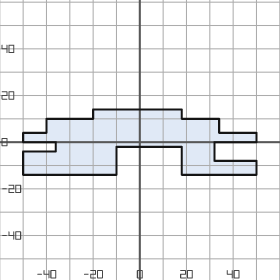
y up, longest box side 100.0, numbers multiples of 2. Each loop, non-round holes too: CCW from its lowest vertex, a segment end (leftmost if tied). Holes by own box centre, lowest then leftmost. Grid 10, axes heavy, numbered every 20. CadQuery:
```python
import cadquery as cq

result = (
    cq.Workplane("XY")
    .moveTo(-50.0, -14.0)
    .lineTo(-10.0, -14.0)
    .lineTo(-10.0, -2.0)
    .lineTo(18.0, -2.0)
    .lineTo(18.0, -14.0)
    .lineTo(50.0, -14.0)
    .lineTo(50.0, -8.0)
    .lineTo(32.0, -8.0)
    .lineTo(32.0, 0.0)
    .lineTo(50.0, 0.0)
    .lineTo(50.0, 4.0)
    .lineTo(34.0, 4.0)
    .lineTo(34.0, 10.0)
    .lineTo(18.0, 10.0)
    .lineTo(18.0, 14.0)
    .lineTo(-20.0, 14.0)
    .lineTo(-20.0, 10.0)
    .lineTo(-40.0, 10.0)
    .lineTo(-40.0, 4.0)
    .lineTo(-50.0, 4.0)
    .lineTo(-50.0, 0.0)
    .lineTo(-36.0, 0.0)
    .lineTo(-36.0, -4.0)
    .lineTo(-50.0, -4.0)
    .close()
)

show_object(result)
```